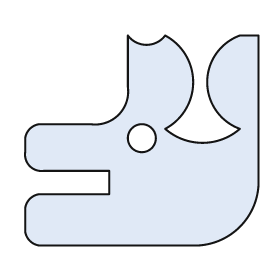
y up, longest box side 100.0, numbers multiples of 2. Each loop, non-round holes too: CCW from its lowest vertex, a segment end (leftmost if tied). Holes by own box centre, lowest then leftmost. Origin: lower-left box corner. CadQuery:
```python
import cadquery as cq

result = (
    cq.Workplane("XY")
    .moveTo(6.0, 0.0)
    .lineTo(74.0, 0.0)
    .threePointArc((92.0, 8.0), (100.0, 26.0))
    .lineTo(100.0, 90.0)
    .lineTo(92.0, 90.0)
    .threePointArc((78.0, 70.0), (92.0, 50.0))
    .threePointArc((76.0, 44.0), (60.0, 50.0))
    .threePointArc((72.0, 70.0), (60.0, 90.0))
    .threePointArc((52.0, 86.0), (44.0, 90.0))
    .lineTo(44.0, 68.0)
    .threePointArc((40.0, 56.0), (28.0, 52.0))
    .lineTo(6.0, 52.0)
    .threePointArc((2.0, 50.0), (0.0, 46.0))
    .lineTo(0.0, 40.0)
    .threePointArc((2.0, 34.0), (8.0, 32.0))
    .lineTo(36.0, 32.0)
    .lineTo(36.0, 22.0)
    .lineTo(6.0, 22.0)
    .threePointArc((2.0, 20.0), (0.0, 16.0))
    .lineTo(0.0, 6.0)
    .threePointArc((2.0, 2.0), (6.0, 0.0))
    .close()
    .moveTo(50.0, 46.0)
    .circle(6.0)
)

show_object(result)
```